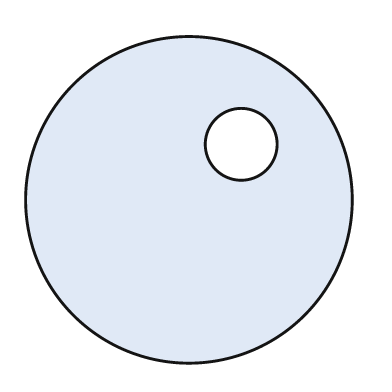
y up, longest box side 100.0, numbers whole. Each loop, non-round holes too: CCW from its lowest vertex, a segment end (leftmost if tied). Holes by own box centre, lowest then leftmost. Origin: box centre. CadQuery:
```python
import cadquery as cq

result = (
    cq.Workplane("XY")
    .moveTo(0.0, 0.0)
    .circle(50.0)
    .moveTo(16.0, 17.0)
    .circle(11.0)
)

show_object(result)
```